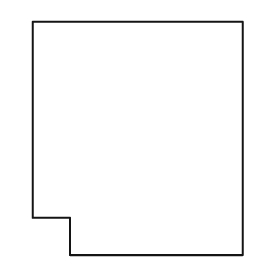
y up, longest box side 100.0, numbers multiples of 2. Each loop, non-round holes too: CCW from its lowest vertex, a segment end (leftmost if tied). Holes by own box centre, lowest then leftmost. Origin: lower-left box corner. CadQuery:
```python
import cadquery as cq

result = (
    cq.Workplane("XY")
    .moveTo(16.0, 0.0)
    .lineTo(90.0, 0.0)
    .lineTo(90.0, 100.0)
    .lineTo(0.0, 100.0)
    .lineTo(0.0, 16.0)
    .lineTo(16.0, 16.0)
    .close()
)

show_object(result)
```